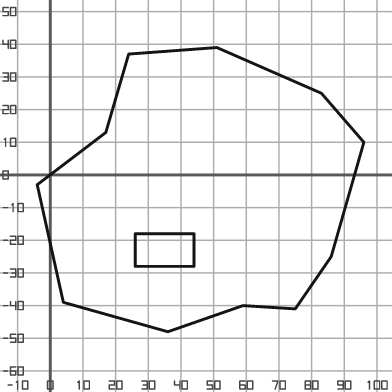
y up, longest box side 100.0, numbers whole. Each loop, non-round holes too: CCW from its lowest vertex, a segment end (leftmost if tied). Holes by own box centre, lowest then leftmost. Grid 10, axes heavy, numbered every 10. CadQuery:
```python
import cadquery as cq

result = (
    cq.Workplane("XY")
    .moveTo(36.0, -48.0)
    .lineTo(59.0, -40.0)
    .lineTo(75.0, -41.0)
    .lineTo(86.0, -25.0)
    .lineTo(96.0, 10.0)
    .lineTo(83.0, 25.0)
    .lineTo(51.0, 39.0)
    .lineTo(24.0, 37.0)
    .lineTo(17.0, 13.0)
    .lineTo(-4.0, -3.0)
    .lineTo(4.0, -39.0)
    .close()
    .moveTo(26.0, -28.0)
    .lineTo(44.0, -28.0)
    .lineTo(44.0, -18.0)
    .lineTo(26.0, -18.0)
    .close()
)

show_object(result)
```